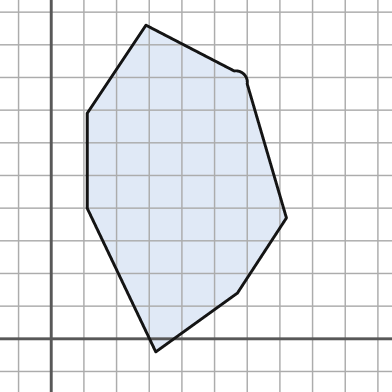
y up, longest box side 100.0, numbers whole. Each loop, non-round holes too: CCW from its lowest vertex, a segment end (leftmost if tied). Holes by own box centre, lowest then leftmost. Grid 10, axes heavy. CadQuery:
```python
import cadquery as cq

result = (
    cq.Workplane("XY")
    .moveTo(32.0, -4.0)
    .lineTo(57.0, 14.0)
    .lineTo(72.0, 37.0)
    .lineTo(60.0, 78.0)
    .threePointArc((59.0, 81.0), (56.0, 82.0))
    .lineTo(29.0, 96.0)
    .lineTo(11.0, 69.0)
    .lineTo(11.0, 40.0)
    .close()
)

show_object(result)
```